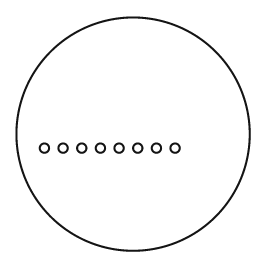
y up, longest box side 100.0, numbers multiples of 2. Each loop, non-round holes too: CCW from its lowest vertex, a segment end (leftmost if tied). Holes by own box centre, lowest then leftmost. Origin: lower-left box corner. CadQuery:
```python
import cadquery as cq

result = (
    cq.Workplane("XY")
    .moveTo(50.0, 50.0)
    .circle(50.0)
    .moveTo(12.0, 44.0)
    .circle(2.0)
    .moveTo(20.0, 44.0)
    .circle(2.0)
    .moveTo(28.0, 44.0)
    .circle(2.0)
    .moveTo(36.0, 44.0)
    .circle(2.0)
    .moveTo(44.0, 44.0)
    .circle(2.0)
    .moveTo(52.0, 44.0)
    .circle(2.0)
    .moveTo(60.0, 44.0)
    .circle(2.0)
    .moveTo(68.0, 44.0)
    .circle(2.0)
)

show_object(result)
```